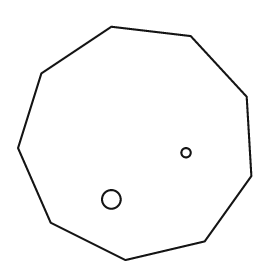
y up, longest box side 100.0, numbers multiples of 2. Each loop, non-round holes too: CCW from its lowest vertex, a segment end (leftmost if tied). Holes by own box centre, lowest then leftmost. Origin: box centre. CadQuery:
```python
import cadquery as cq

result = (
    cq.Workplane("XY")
    .moveTo(-4.0, -50.0)
    .lineTo(30.0, -42.0)
    .lineTo(50.0, -14.0)
    .lineTo(48.0, 20.0)
    .lineTo(24.0, 46.0)
    .lineTo(-10.0, 50.0)
    .lineTo(-40.0, 30.0)
    .lineTo(-50.0, -2.0)
    .lineTo(-36.0, -34.0)
    .close()
    .moveTo(-10.0, -24.0)
    .circle(4.0)
    .moveTo(22.0, -4.0)
    .circle(2.0)
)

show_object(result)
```